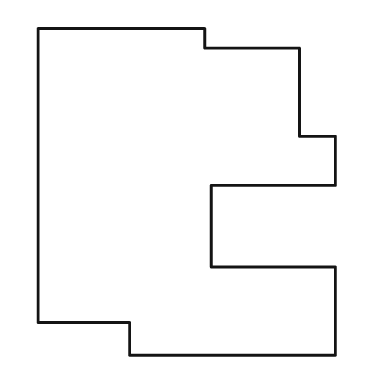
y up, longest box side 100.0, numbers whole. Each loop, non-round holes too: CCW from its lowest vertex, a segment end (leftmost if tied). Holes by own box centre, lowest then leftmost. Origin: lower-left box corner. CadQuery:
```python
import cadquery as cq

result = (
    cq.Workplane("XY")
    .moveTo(28.0, 0.0)
    .lineTo(91.0, 0.0)
    .lineTo(91.0, 27.0)
    .lineTo(53.0, 27.0)
    .lineTo(53.0, 52.0)
    .lineTo(91.0, 52.0)
    .lineTo(91.0, 67.0)
    .lineTo(80.0, 67.0)
    .lineTo(80.0, 94.0)
    .lineTo(51.0, 94.0)
    .lineTo(51.0, 100.0)
    .lineTo(0.0, 100.0)
    .lineTo(0.0, 10.0)
    .lineTo(28.0, 10.0)
    .close()
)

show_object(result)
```